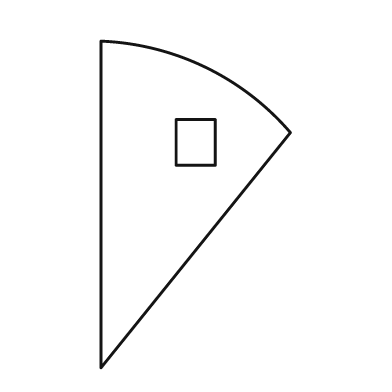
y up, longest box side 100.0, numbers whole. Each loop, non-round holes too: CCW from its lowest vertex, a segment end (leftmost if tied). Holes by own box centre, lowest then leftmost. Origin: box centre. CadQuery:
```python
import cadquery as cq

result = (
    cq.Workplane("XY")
    .moveTo(-29.0, -50.0)
    .lineTo(29.0, 22.0)
    .threePointArc((3.0, 42.0), (-29.0, 50.0))
    .close()
    .moveTo(-6.0, 12.0)
    .lineTo(6.0, 12.0)
    .lineTo(6.0, 26.0)
    .lineTo(-6.0, 26.0)
    .close()
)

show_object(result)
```